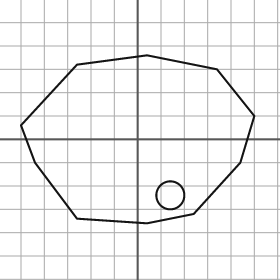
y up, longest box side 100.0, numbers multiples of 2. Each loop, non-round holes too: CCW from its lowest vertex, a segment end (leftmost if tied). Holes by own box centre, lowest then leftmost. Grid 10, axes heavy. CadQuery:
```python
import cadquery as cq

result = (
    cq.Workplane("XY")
    .moveTo(4.0, -36.0)
    .lineTo(24.0, -32.0)
    .lineTo(44.0, -10.0)
    .lineTo(50.0, 10.0)
    .lineTo(34.0, 30.0)
    .lineTo(4.0, 36.0)
    .lineTo(-26.0, 32.0)
    .lineTo(-50.0, 6.0)
    .lineTo(-44.0, -10.0)
    .lineTo(-26.0, -34.0)
    .close()
    .moveTo(14.0, -24.0)
    .circle(6.0)
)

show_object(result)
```